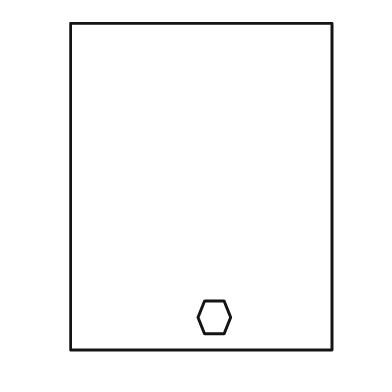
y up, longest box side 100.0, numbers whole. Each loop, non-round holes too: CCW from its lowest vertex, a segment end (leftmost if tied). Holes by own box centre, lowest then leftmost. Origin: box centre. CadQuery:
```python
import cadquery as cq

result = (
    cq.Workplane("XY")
    .moveTo(-40.0, -50.0)
    .lineTo(40.0, -50.0)
    .lineTo(40.0, 50.0)
    .lineTo(-40.0, 50.0)
    .close()
    .moveTo(1.0, -45.0)
    .lineTo(7.0, -45.0)
    .lineTo(9.0, -40.0)
    .lineTo(7.0, -35.0)
    .lineTo(1.0, -35.0)
    .lineTo(-1.0, -40.0)
    .close()
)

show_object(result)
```